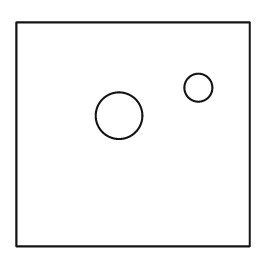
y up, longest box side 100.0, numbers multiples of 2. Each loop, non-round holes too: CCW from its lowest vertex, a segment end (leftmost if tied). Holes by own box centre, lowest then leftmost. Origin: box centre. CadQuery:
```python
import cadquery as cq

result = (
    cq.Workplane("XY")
    .moveTo(-50.0, -48.0)
    .lineTo(50.0, -48.0)
    .lineTo(50.0, 48.0)
    .lineTo(-50.0, 48.0)
    .close()
    .moveTo(-6.0, 8.0)
    .circle(10.0)
    .moveTo(28.0, 20.0)
    .circle(6.0)
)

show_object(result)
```